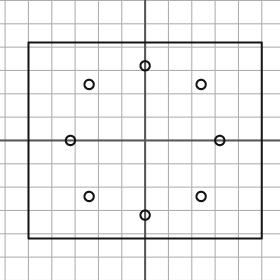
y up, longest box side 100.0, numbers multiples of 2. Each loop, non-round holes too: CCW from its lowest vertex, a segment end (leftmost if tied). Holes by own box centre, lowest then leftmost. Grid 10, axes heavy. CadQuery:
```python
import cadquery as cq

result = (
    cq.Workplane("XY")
    .moveTo(-50.0, -42.0)
    .lineTo(50.0, -42.0)
    .lineTo(50.0, 42.0)
    .lineTo(-50.0, 42.0)
    .close()
    .moveTo(0.0, -32.0)
    .circle(2.0)
    .moveTo(-24.0, -24.0)
    .circle(2.0)
    .moveTo(24.0, -24.0)
    .circle(2.0)
    .moveTo(-32.0, 0.0)
    .circle(2.0)
    .moveTo(32.0, 0.0)
    .circle(2.0)
    .moveTo(-24.0, 24.0)
    .circle(2.0)
    .moveTo(24.0, 24.0)
    .circle(2.0)
    .moveTo(0.0, 32.0)
    .circle(2.0)
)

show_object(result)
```